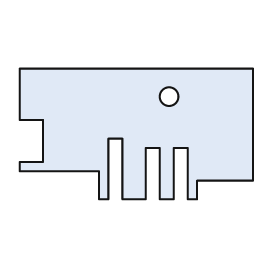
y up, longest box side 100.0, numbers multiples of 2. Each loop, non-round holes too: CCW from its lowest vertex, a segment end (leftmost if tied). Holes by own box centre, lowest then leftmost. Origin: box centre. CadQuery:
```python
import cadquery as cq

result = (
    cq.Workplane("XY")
    .moveTo(-16.0, -28.0)
    .lineTo(-12.0, -28.0)
    .lineTo(-12.0, -2.0)
    .lineTo(-6.0, -2.0)
    .lineTo(-6.0, -28.0)
    .lineTo(4.0, -28.0)
    .lineTo(4.0, -6.0)
    .lineTo(10.0, -6.0)
    .lineTo(10.0, -28.0)
    .lineTo(16.0, -28.0)
    .lineTo(16.0, -6.0)
    .lineTo(22.0, -6.0)
    .lineTo(22.0, -28.0)
    .lineTo(26.0, -28.0)
    .lineTo(26.0, -20.0)
    .lineTo(50.0, -20.0)
    .lineTo(50.0, 28.0)
    .lineTo(-50.0, 28.0)
    .lineTo(-50.0, 6.0)
    .lineTo(-40.0, 6.0)
    .lineTo(-40.0, -12.0)
    .lineTo(-50.0, -12.0)
    .lineTo(-50.0, -16.0)
    .lineTo(-16.0, -16.0)
    .close()
    .moveTo(14.0, 16.0)
    .circle(4.0)
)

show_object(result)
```